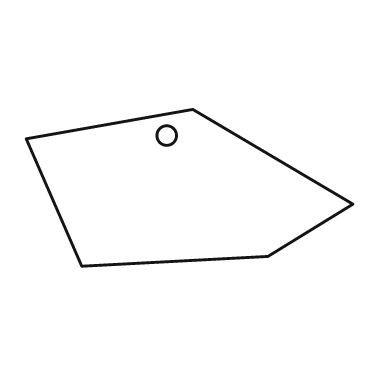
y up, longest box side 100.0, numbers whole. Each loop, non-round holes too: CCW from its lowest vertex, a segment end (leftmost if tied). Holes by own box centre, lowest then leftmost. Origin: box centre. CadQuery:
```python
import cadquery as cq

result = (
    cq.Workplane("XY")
    .moveTo(-33.0, -24.0)
    .lineTo(24.0, -21.0)
    .lineTo(50.0, -5.0)
    .lineTo(1.0, 24.0)
    .lineTo(-50.0, 15.0)
    .close()
    .moveTo(-7.0, 16.0)
    .circle(3.0)
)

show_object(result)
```